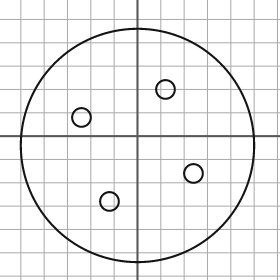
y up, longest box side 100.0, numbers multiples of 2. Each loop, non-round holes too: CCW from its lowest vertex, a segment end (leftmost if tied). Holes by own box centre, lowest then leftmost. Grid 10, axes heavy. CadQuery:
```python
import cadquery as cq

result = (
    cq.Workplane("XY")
    .moveTo(0.0, -4.0)
    .circle(50.0)
    .moveTo(-12.0, -28.0)
    .circle(4.0)
    .moveTo(24.0, -16.0)
    .circle(4.0)
    .moveTo(-24.0, 8.0)
    .circle(4.0)
    .moveTo(12.0, 20.0)
    .circle(4.0)
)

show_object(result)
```